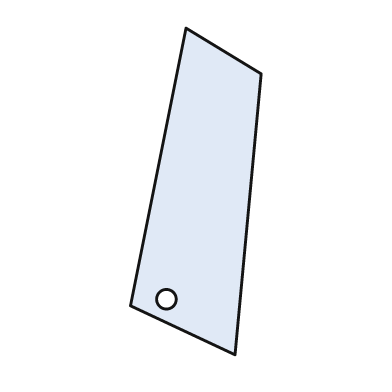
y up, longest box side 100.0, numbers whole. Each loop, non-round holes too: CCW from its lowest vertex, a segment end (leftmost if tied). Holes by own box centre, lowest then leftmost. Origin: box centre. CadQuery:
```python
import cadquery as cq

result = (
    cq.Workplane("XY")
    .moveTo(12.0, -50.0)
    .lineTo(20.0, 36.0)
    .lineTo(-3.0, 50.0)
    .lineTo(-20.0, -35.0)
    .close()
    .moveTo(-9.0, -33.0)
    .circle(3.0)
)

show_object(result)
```